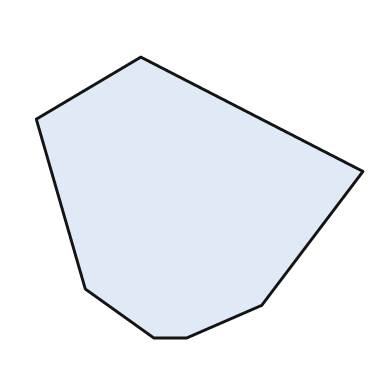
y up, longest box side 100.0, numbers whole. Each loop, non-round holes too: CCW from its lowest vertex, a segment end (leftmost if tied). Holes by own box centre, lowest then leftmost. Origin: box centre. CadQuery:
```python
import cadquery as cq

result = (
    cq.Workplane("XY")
    .moveTo(-14.0, -43.0)
    .lineTo(-4.0, -43.0)
    .lineTo(19.0, -33.0)
    .lineTo(50.0, 8.0)
    .lineTo(-18.0, 43.0)
    .lineTo(-50.0, 24.0)
    .lineTo(-35.0, -28.0)
    .close()
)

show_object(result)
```